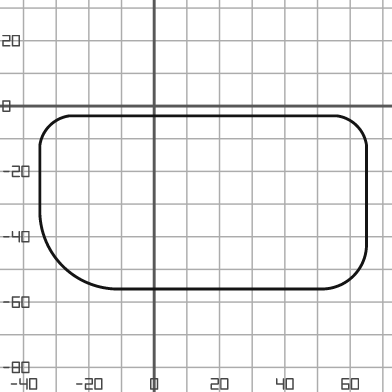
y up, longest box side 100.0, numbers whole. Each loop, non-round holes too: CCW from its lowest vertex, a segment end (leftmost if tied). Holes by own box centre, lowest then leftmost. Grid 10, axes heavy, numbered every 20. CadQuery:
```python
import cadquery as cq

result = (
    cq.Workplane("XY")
    .moveTo(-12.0, -56.0)
    .lineTo(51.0, -56.0)
    .threePointArc((61.0, -52.0), (65.0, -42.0))
    .lineTo(65.0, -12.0)
    .threePointArc((62.0, -6.0), (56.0, -3.0))
    .lineTo(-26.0, -3.0)
    .threePointArc((-32.0, -6.0), (-35.0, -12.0))
    .lineTo(-35.0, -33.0)
    .threePointArc((-28.0, -49.0), (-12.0, -56.0))
    .close()
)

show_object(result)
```